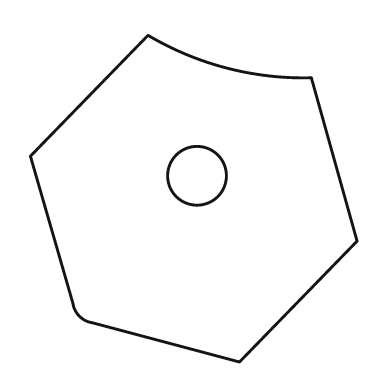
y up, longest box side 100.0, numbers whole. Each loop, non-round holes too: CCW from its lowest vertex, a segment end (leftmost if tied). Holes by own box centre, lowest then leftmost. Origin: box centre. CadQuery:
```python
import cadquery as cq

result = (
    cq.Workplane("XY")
    .moveTo(14.0, -50.0)
    .lineTo(50.0, -13.0)
    .lineTo(36.0, 37.0)
    .threePointArc((10.0, 40.0), (-14.0, 50.0))
    .lineTo(-50.0, 13.0)
    .lineTo(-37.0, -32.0)
    .threePointArc((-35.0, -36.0), (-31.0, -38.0))
    .close()
    .moveTo(1.0, 7.0)
    .circle(9.0)
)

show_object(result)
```